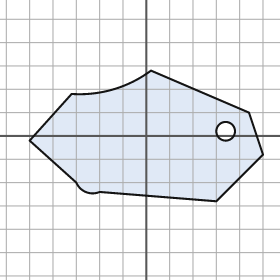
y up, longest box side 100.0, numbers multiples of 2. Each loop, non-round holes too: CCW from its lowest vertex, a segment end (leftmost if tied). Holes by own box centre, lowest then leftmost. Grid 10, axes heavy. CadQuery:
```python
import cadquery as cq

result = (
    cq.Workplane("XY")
    .moveTo(30.0, -28.0)
    .lineTo(50.0, -8.0)
    .lineTo(44.0, 10.0)
    .lineTo(2.0, 28.0)
    .threePointArc((-14.0, 20.0), (-32.0, 18.0))
    .lineTo(-50.0, -2.0)
    .lineTo(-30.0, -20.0)
    .threePointArc((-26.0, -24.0), (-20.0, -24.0))
    .close()
    .moveTo(34.0, 2.0)
    .circle(4.0)
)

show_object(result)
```